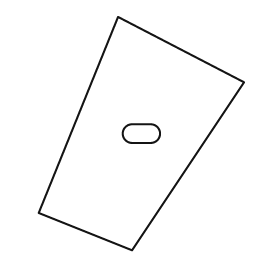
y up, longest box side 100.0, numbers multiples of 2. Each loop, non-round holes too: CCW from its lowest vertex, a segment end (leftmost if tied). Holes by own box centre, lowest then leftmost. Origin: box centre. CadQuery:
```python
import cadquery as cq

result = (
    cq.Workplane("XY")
    .moveTo(-4.0, -50.0)
    .lineTo(44.0, 22.0)
    .lineTo(-10.0, 50.0)
    .lineTo(-44.0, -34.0)
    .close()
    .moveTo(-4.0, -4.0)
    .lineTo(4.0, -4.0)
    .threePointArc((8.0, 0.0), (4.0, 4.0))
    .lineTo(-4.0, 4.0)
    .threePointArc((-8.0, 0.0), (-4.0, -4.0))
    .close()
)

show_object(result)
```